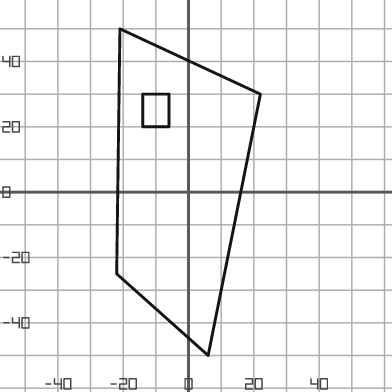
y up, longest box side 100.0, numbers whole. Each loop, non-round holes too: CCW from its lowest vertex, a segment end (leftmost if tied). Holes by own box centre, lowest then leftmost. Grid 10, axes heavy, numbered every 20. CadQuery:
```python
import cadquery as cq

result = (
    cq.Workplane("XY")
    .moveTo(6.0, -50.0)
    .lineTo(22.0, 30.0)
    .lineTo(-21.0, 50.0)
    .lineTo(-22.0, -25.0)
    .close()
    .moveTo(-14.0, 20.0)
    .lineTo(-6.0, 20.0)
    .lineTo(-6.0, 30.0)
    .lineTo(-14.0, 30.0)
    .close()
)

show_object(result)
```